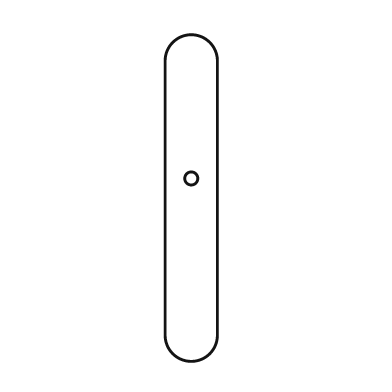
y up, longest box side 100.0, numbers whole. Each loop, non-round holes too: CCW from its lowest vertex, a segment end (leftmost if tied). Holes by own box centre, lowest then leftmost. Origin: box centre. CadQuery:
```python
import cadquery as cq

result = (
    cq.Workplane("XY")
    .moveTo(-8.0, -42.0)
    .threePointArc((0.0, -50.0), (8.0, -42.0))
    .lineTo(8.0, 42.0)
    .threePointArc((0.0, 50.0), (-8.0, 42.0))
    .close()
    .moveTo(0.0, 6.0)
    .circle(2.0)
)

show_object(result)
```